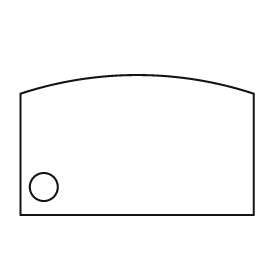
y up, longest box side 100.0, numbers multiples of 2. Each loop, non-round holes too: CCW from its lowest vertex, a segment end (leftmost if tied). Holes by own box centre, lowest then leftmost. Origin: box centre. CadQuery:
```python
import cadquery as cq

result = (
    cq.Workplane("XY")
    .moveTo(-50.0, -30.0)
    .lineTo(50.0, -30.0)
    .lineTo(50.0, 22.0)
    .threePointArc((0.0, 30.0), (-50.0, 22.0))
    .close()
    .moveTo(-40.0, -18.0)
    .circle(6.0)
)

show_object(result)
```